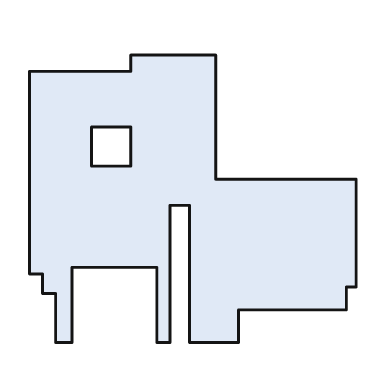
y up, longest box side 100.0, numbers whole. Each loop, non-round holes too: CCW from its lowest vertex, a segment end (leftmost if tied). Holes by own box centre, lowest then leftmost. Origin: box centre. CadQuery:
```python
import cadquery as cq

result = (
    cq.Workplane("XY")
    .moveTo(-42.0, -44.0)
    .lineTo(-37.0, -44.0)
    .lineTo(-37.0, -21.0)
    .lineTo(-11.0, -21.0)
    .lineTo(-11.0, -44.0)
    .lineTo(-7.0, -44.0)
    .lineTo(-7.0, -2.0)
    .lineTo(-1.0, -2.0)
    .lineTo(-1.0, -44.0)
    .lineTo(14.0, -44.0)
    .lineTo(14.0, -34.0)
    .lineTo(47.0, -34.0)
    .lineTo(47.0, -27.0)
    .lineTo(50.0, -27.0)
    .lineTo(50.0, 6.0)
    .lineTo(7.0, 6.0)
    .lineTo(7.0, 44.0)
    .lineTo(-19.0, 44.0)
    .lineTo(-19.0, 39.0)
    .lineTo(-50.0, 39.0)
    .lineTo(-50.0, -23.0)
    .lineTo(-46.0, -23.0)
    .lineTo(-46.0, -29.0)
    .lineTo(-42.0, -29.0)
    .close()
    .moveTo(-31.0, 10.0)
    .lineTo(-19.0, 10.0)
    .lineTo(-19.0, 22.0)
    .lineTo(-31.0, 22.0)
    .close()
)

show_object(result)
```